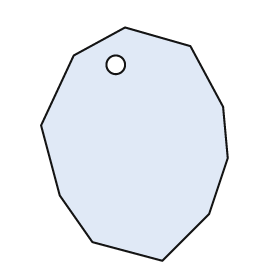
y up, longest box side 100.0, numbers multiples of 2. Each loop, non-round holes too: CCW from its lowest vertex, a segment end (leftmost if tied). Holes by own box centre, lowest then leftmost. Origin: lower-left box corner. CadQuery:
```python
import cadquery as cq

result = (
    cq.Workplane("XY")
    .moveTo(52.0, 0.0)
    .lineTo(72.0, 20.0)
    .lineTo(80.0, 44.0)
    .lineTo(78.0, 66.0)
    .lineTo(64.0, 92.0)
    .lineTo(36.0, 100.0)
    .lineTo(14.0, 88.0)
    .lineTo(0.0, 58.0)
    .lineTo(8.0, 28.0)
    .lineTo(22.0, 8.0)
    .close()
    .moveTo(32.0, 84.0)
    .circle(4.0)
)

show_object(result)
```